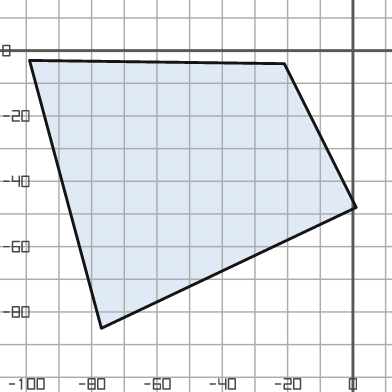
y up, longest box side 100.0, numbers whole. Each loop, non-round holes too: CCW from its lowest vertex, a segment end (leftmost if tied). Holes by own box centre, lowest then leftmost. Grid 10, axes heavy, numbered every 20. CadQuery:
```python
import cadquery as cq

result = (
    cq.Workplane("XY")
    .moveTo(-77.0, -85.0)
    .lineTo(1.0, -48.0)
    .lineTo(-21.0, -4.0)
    .lineTo(-99.0, -3.0)
    .close()
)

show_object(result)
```